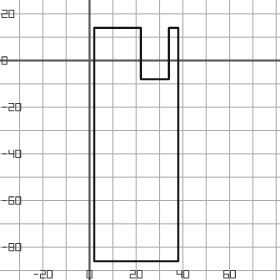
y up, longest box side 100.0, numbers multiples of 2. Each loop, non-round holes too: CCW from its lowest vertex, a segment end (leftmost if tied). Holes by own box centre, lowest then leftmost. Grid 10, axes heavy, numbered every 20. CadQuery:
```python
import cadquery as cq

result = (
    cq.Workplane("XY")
    .moveTo(2.0, -86.0)
    .lineTo(38.0, -86.0)
    .lineTo(38.0, 14.0)
    .lineTo(34.0, 14.0)
    .lineTo(34.0, -8.0)
    .lineTo(22.0, -8.0)
    .lineTo(22.0, 14.0)
    .lineTo(2.0, 14.0)
    .close()
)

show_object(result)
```